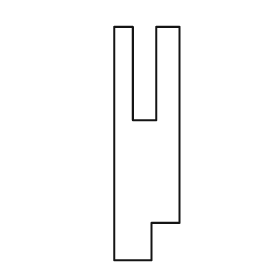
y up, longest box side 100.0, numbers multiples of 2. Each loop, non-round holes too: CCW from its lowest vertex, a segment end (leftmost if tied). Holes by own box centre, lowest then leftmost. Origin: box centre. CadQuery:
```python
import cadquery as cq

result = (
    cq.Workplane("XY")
    .moveTo(-14.0, -50.0)
    .lineTo(2.0, -50.0)
    .lineTo(2.0, -34.0)
    .lineTo(14.0, -34.0)
    .lineTo(14.0, 50.0)
    .lineTo(4.0, 50.0)
    .lineTo(4.0, 10.0)
    .lineTo(-6.0, 10.0)
    .lineTo(-6.0, 50.0)
    .lineTo(-14.0, 50.0)
    .close()
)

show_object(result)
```